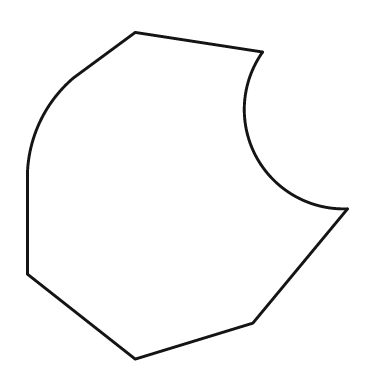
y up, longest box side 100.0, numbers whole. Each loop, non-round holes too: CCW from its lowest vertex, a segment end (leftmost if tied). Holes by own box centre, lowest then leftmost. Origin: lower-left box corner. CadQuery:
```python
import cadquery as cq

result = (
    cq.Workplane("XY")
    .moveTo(33.0, 0.0)
    .lineTo(69.0, 11.0)
    .lineTo(98.0, 46.0)
    .threePointArc((70.0, 62.0), (72.0, 94.0))
    .lineTo(33.0, 100.0)
    .lineTo(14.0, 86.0)
    .threePointArc((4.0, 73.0), (0.0, 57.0))
    .lineTo(0.0, 26.0)
    .close()
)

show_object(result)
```